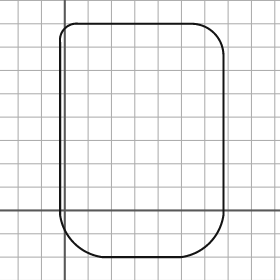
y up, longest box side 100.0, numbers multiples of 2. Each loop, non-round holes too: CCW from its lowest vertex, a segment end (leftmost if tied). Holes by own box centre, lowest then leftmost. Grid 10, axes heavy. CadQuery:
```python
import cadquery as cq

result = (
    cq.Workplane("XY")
    .moveTo(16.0, -20.0)
    .lineTo(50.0, -20.0)
    .threePointArc((62.0, -14.0), (68.0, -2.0))
    .lineTo(68.0, 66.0)
    .threePointArc((64.0, 76.0), (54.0, 80.0))
    .lineTo(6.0, 80.0)
    .threePointArc((0.0, 78.0), (-2.0, 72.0))
    .lineTo(-2.0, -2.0)
    .threePointArc((4.0, -14.0), (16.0, -20.0))
    .close()
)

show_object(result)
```